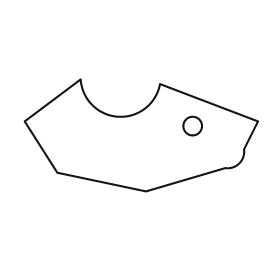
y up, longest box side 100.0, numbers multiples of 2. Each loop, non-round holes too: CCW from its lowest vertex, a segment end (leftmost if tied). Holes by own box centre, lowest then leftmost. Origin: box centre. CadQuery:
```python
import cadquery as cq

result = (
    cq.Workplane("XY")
    .moveTo(2.0, -24.0)
    .lineTo(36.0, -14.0)
    .threePointArc((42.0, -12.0), (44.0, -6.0))
    .lineTo(50.0, 6.0)
    .lineTo(8.0, 22.0)
    .threePointArc((-10.0, 8.0), (-26.0, 24.0))
    .lineTo(-50.0, 6.0)
    .lineTo(-36.0, -16.0)
    .close()
    .moveTo(22.0, 4.0)
    .circle(4.0)
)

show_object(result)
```